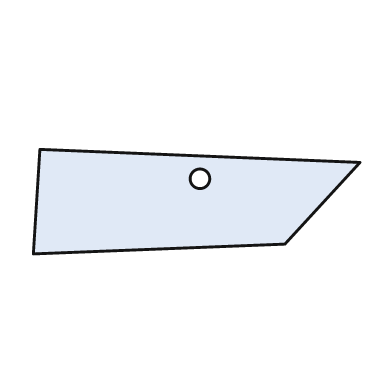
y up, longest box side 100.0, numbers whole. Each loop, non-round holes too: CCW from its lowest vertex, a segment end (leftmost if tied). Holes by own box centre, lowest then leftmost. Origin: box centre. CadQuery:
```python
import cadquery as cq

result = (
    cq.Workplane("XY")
    .moveTo(-50.0, -16.0)
    .lineTo(27.0, -13.0)
    .lineTo(50.0, 12.0)
    .lineTo(-48.0, 16.0)
    .close()
    .moveTo(1.0, 7.0)
    .circle(3.0)
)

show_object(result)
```